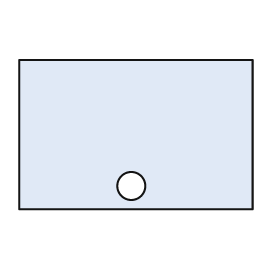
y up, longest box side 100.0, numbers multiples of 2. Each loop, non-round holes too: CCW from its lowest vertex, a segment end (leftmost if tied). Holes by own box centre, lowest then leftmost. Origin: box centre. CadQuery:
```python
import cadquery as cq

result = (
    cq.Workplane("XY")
    .moveTo(-50.0, -32.0)
    .lineTo(50.0, -32.0)
    .lineTo(50.0, 32.0)
    .lineTo(-50.0, 32.0)
    .close()
    .moveTo(-2.0, -22.0)
    .circle(6.0)
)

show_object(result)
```